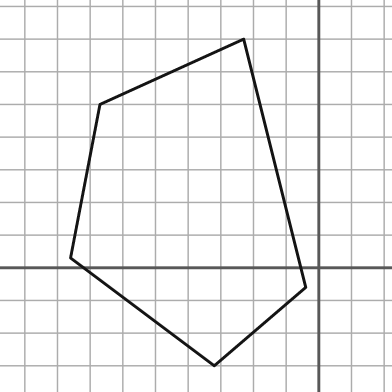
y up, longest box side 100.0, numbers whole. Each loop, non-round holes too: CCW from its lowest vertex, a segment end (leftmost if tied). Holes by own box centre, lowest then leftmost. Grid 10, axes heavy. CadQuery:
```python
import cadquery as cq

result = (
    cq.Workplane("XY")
    .moveTo(-32.0, -30.0)
    .lineTo(-4.0, -6.0)
    .lineTo(-23.0, 70.0)
    .lineTo(-67.0, 50.0)
    .lineTo(-76.0, 3.0)
    .close()
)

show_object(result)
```